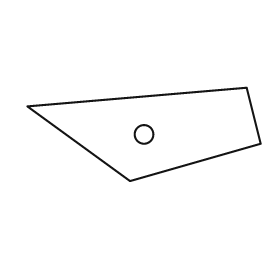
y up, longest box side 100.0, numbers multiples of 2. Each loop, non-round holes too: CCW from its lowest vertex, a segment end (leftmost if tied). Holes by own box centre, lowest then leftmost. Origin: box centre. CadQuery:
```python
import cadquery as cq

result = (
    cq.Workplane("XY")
    .moveTo(-6.0, -20.0)
    .lineTo(50.0, -4.0)
    .lineTo(44.0, 20.0)
    .lineTo(-50.0, 12.0)
    .close()
    .moveTo(0.0, 0.0)
    .circle(4.0)
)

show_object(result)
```